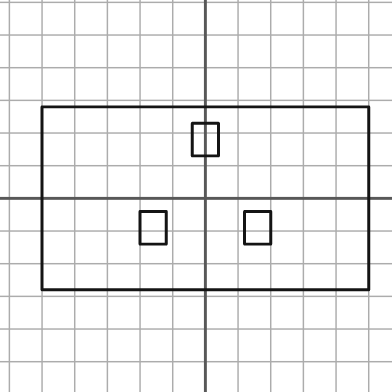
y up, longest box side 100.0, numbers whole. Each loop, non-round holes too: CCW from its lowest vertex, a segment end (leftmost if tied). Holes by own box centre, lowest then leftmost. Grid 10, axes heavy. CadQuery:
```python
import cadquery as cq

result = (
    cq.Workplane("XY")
    .moveTo(-50.0, -28.0)
    .lineTo(50.0, -28.0)
    .lineTo(50.0, 28.0)
    .lineTo(-50.0, 28.0)
    .close()
    .moveTo(-20.0, -14.0)
    .lineTo(-12.0, -14.0)
    .lineTo(-12.0, -4.0)
    .lineTo(-20.0, -4.0)
    .close()
    .moveTo(12.0, -14.0)
    .lineTo(20.0, -14.0)
    .lineTo(20.0, -4.0)
    .lineTo(12.0, -4.0)
    .close()
    .moveTo(-4.0, 13.0)
    .lineTo(4.0, 13.0)
    .lineTo(4.0, 23.0)
    .lineTo(-4.0, 23.0)
    .close()
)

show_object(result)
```